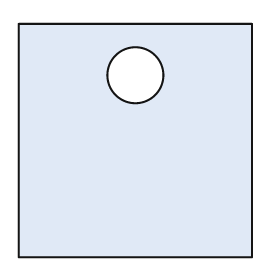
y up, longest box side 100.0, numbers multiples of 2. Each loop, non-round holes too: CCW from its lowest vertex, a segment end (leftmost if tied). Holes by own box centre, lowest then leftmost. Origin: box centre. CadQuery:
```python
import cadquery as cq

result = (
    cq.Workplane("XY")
    .moveTo(-50.0, -50.0)
    .lineTo(50.0, -50.0)
    .lineTo(50.0, 50.0)
    .lineTo(-50.0, 50.0)
    .close()
    .moveTo(0.0, 28.0)
    .circle(12.0)
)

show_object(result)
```